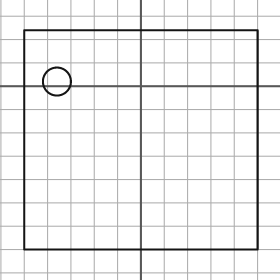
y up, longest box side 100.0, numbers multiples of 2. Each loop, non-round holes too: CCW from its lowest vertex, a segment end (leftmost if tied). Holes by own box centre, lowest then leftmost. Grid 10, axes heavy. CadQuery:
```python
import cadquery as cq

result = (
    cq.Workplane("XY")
    .moveTo(-50.0, -70.0)
    .lineTo(50.0, -70.0)
    .lineTo(50.0, 24.0)
    .lineTo(-50.0, 24.0)
    .close()
    .moveTo(-36.0, 2.0)
    .circle(6.0)
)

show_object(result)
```